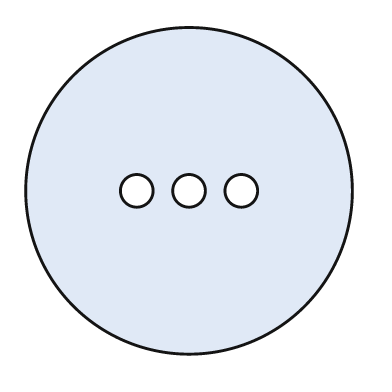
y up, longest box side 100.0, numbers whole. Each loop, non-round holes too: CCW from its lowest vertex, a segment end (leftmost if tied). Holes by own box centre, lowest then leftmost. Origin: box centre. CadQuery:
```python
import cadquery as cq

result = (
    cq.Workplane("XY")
    .moveTo(0.0, 0.0)
    .circle(50.0)
    .moveTo(-16.0, 0.0)
    .circle(5.0)
    .moveTo(0.0, 0.0)
    .circle(5.0)
    .moveTo(16.0, 0.0)
    .circle(5.0)
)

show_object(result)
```